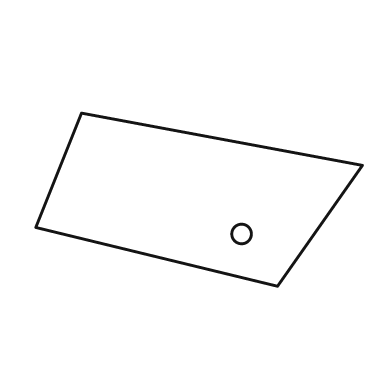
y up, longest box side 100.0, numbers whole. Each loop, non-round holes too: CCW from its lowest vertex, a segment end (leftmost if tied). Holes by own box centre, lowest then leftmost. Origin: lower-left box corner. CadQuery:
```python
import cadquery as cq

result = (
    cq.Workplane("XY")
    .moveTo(74.0, 0.0)
    .lineTo(100.0, 37.0)
    .lineTo(14.0, 53.0)
    .lineTo(0.0, 18.0)
    .close()
    .moveTo(63.0, 16.0)
    .circle(3.0)
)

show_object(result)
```